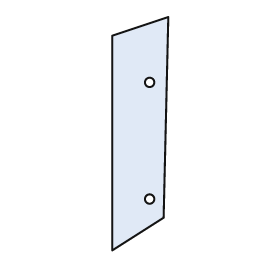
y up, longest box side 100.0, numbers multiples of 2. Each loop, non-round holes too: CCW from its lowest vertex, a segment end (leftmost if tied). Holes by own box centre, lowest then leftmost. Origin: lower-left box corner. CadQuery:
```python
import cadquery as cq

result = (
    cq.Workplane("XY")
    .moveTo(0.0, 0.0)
    .lineTo(22.0, 14.0)
    .lineTo(24.0, 100.0)
    .lineTo(0.0, 92.0)
    .close()
    .moveTo(16.0, 22.0)
    .circle(2.0)
    .moveTo(16.0, 72.0)
    .circle(2.0)
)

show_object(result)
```